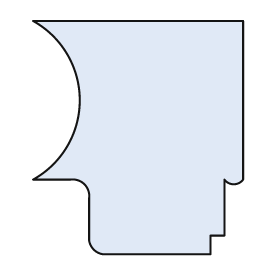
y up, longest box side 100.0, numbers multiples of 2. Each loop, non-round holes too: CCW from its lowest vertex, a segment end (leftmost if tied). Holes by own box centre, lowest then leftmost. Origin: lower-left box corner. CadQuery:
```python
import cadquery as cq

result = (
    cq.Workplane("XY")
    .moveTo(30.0, 0.0)
    .lineTo(76.0, 0.0)
    .lineTo(76.0, 8.0)
    .lineTo(82.0, 8.0)
    .lineTo(82.0, 32.0)
    .threePointArc((86.0, 30.0), (90.0, 32.0))
    .lineTo(90.0, 100.0)
    .lineTo(0.0, 100.0)
    .threePointArc((20.0, 66.0), (0.0, 32.0))
    .lineTo(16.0, 32.0)
    .threePointArc((22.0, 30.0), (24.0, 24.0))
    .lineTo(24.0, 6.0)
    .threePointArc((26.0, 2.0), (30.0, 0.0))
    .close()
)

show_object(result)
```